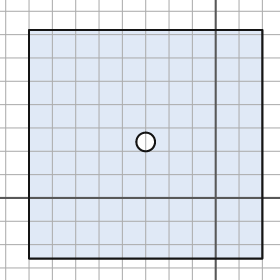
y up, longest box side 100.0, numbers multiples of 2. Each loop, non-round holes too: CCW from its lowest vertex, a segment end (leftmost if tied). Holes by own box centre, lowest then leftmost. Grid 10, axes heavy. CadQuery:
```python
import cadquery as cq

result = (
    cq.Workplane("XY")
    .moveTo(-80.0, -26.0)
    .lineTo(20.0, -26.0)
    .lineTo(20.0, 72.0)
    .lineTo(-80.0, 72.0)
    .close()
    .moveTo(-30.0, 24.0)
    .circle(4.0)
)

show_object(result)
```